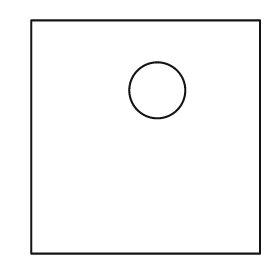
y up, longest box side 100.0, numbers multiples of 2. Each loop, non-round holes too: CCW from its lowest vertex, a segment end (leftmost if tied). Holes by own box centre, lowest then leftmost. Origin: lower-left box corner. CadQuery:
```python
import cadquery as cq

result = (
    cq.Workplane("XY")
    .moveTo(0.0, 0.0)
    .lineTo(98.0, 0.0)
    .lineTo(98.0, 100.0)
    .lineTo(0.0, 100.0)
    .close()
    .moveTo(54.0, 70.0)
    .circle(12.0)
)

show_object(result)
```